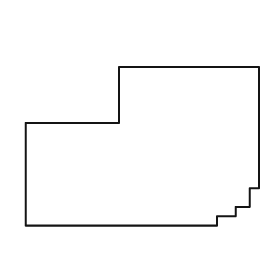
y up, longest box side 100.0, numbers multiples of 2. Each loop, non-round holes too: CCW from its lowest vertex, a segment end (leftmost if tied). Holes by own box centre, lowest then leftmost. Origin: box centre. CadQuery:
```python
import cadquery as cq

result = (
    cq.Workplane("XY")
    .moveTo(-50.0, -34.0)
    .lineTo(32.0, -34.0)
    .lineTo(32.0, -30.0)
    .lineTo(40.0, -30.0)
    .lineTo(40.0, -26.0)
    .lineTo(46.0, -26.0)
    .lineTo(46.0, -18.0)
    .lineTo(50.0, -18.0)
    .lineTo(50.0, 34.0)
    .lineTo(-10.0, 34.0)
    .lineTo(-10.0, 10.0)
    .lineTo(-50.0, 10.0)
    .close()
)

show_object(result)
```